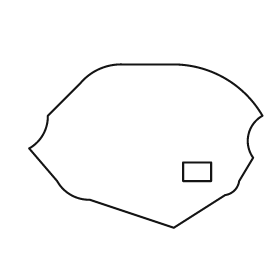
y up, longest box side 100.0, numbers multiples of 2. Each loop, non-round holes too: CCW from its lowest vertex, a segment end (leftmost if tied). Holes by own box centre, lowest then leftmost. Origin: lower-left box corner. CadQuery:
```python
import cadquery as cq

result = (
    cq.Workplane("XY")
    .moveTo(62.0, 0.0)
    .lineTo(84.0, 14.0)
    .threePointArc((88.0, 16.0), (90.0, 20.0))
    .lineTo(96.0, 30.0)
    .threePointArc((94.0, 40.0), (100.0, 48.0))
    .threePointArc((84.0, 64.0), (62.0, 70.0))
    .lineTo(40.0, 70.0)
    .threePointArc((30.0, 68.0), (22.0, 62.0))
    .lineTo(8.0, 48.0)
    .threePointArc((6.0, 40.0), (0.0, 34.0))
    .lineTo(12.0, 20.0)
    .threePointArc((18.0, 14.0), (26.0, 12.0))
    .close()
    .moveTo(66.0, 20.0)
    .lineTo(78.0, 20.0)
    .lineTo(78.0, 28.0)
    .lineTo(66.0, 28.0)
    .close()
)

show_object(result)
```